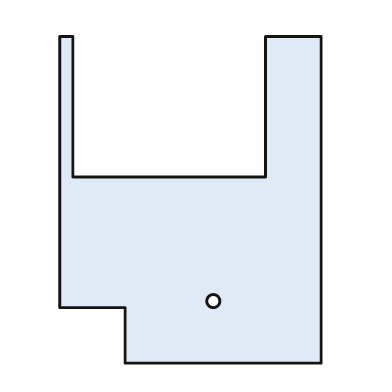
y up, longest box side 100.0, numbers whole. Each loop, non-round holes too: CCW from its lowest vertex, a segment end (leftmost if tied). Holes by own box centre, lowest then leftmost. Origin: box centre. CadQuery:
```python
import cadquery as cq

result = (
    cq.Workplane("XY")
    .moveTo(-20.0, -50.0)
    .lineTo(40.0, -50.0)
    .lineTo(40.0, 50.0)
    .lineTo(23.0, 50.0)
    .lineTo(23.0, 7.0)
    .lineTo(-36.0, 7.0)
    .lineTo(-36.0, 50.0)
    .lineTo(-40.0, 50.0)
    .lineTo(-40.0, -33.0)
    .lineTo(-20.0, -33.0)
    .close()
    .moveTo(7.0, -31.0)
    .circle(2.0)
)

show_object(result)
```